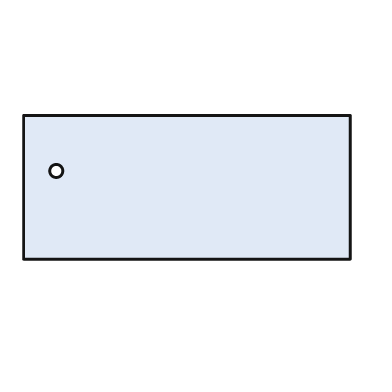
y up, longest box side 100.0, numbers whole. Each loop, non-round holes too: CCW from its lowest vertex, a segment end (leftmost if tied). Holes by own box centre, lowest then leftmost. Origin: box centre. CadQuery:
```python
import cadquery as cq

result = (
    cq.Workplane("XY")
    .moveTo(-50.0, -22.0)
    .lineTo(50.0, -22.0)
    .lineTo(50.0, 22.0)
    .lineTo(-50.0, 22.0)
    .close()
    .moveTo(-40.0, 5.0)
    .circle(2.0)
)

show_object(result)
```